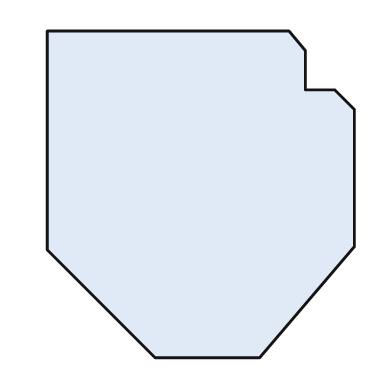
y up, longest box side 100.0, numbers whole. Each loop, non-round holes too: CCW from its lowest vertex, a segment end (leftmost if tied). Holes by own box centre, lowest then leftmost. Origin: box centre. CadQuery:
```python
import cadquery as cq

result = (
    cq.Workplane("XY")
    .moveTo(-14.0, -50.0)
    .lineTo(18.0, -50.0)
    .lineTo(47.0, -16.0)
    .lineTo(47.0, 26.0)
    .lineTo(41.0, 32.0)
    .lineTo(32.0, 32.0)
    .lineTo(32.0, 44.0)
    .lineTo(27.0, 50.0)
    .lineTo(-47.0, 50.0)
    .lineTo(-47.0, -17.0)
    .close()
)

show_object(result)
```